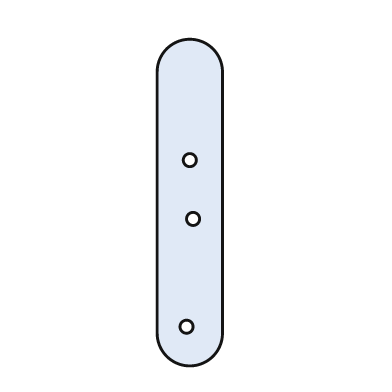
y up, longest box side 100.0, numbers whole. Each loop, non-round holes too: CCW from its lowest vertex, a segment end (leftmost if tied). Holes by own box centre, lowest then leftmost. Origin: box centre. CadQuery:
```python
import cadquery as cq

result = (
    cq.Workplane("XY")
    .moveTo(-10.0, -40.0)
    .threePointArc((0.0, -50.0), (10.0, -40.0))
    .lineTo(10.0, 40.0)
    .threePointArc((0.0, 50.0), (-10.0, 40.0))
    .close()
    .moveTo(-1.0, -38.0)
    .circle(2.0)
    .moveTo(1.0, -5.0)
    .circle(2.0)
    .moveTo(0.0, 13.0)
    .circle(2.0)
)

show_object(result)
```